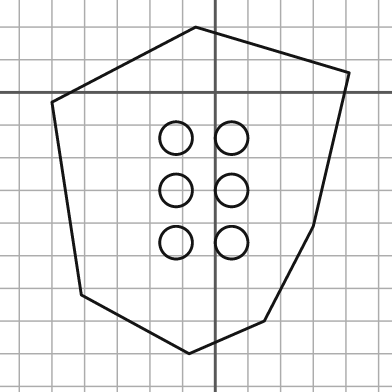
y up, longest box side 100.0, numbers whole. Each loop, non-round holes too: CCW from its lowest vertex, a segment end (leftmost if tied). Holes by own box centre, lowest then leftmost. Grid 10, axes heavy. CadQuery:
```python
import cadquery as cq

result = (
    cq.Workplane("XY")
    .moveTo(-8.0, -80.0)
    .lineTo(15.0, -70.0)
    .lineTo(30.0, -41.0)
    .lineTo(41.0, 6.0)
    .lineTo(-6.0, 20.0)
    .lineTo(-50.0, -3.0)
    .lineTo(-41.0, -62.0)
    .close()
    .moveTo(-12.0, -46.0)
    .circle(5.0)
    .moveTo(5.0, -46.0)
    .circle(5.0)
    .moveTo(-12.0, -30.0)
    .circle(5.0)
    .moveTo(5.0, -30.0)
    .circle(5.0)
    .moveTo(-12.0, -14.0)
    .circle(5.0)
    .moveTo(5.0, -14.0)
    .circle(5.0)
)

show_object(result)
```